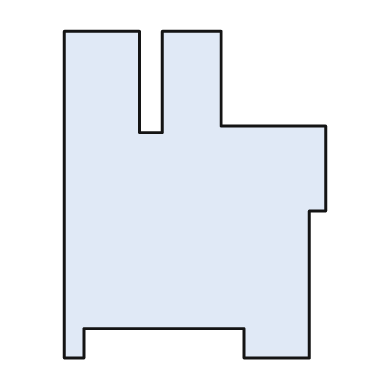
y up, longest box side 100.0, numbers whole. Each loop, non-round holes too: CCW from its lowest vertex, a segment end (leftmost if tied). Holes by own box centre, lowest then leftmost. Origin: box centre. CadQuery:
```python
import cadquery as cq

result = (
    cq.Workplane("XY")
    .moveTo(-40.0, -50.0)
    .lineTo(-34.0, -50.0)
    .lineTo(-34.0, -41.0)
    .lineTo(15.0, -41.0)
    .lineTo(15.0, -50.0)
    .lineTo(35.0, -50.0)
    .lineTo(35.0, -5.0)
    .lineTo(40.0, -5.0)
    .lineTo(40.0, 21.0)
    .lineTo(8.0, 21.0)
    .lineTo(8.0, 50.0)
    .lineTo(-10.0, 50.0)
    .lineTo(-10.0, 19.0)
    .lineTo(-17.0, 19.0)
    .lineTo(-17.0, 50.0)
    .lineTo(-40.0, 50.0)
    .close()
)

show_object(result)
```